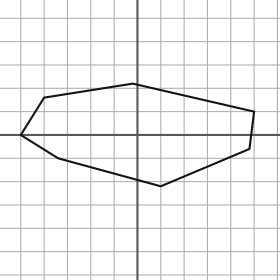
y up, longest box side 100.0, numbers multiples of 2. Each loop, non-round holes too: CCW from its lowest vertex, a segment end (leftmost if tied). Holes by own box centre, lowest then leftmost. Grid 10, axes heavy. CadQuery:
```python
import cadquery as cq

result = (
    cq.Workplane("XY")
    .moveTo(10.0, -22.0)
    .lineTo(48.0, -6.0)
    .lineTo(50.0, 10.0)
    .lineTo(-2.0, 22.0)
    .lineTo(-40.0, 16.0)
    .lineTo(-50.0, 0.0)
    .lineTo(-34.0, -10.0)
    .close()
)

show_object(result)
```